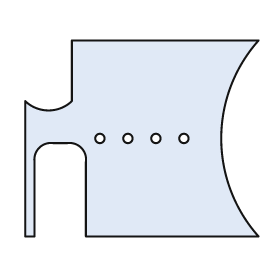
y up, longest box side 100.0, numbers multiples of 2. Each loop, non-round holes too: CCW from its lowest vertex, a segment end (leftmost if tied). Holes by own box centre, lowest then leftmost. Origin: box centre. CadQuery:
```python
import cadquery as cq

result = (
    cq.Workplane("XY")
    .moveTo(-50.0, -42.0)
    .lineTo(-46.0, -42.0)
    .lineTo(-46.0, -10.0)
    .threePointArc((-44.0, -4.0), (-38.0, -2.0))
    .lineTo(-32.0, -2.0)
    .threePointArc((-26.0, -4.0), (-24.0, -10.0))
    .lineTo(-24.0, -42.0)
    .lineTo(50.0, -42.0)
    .threePointArc((34.0, 0.0), (50.0, 42.0))
    .lineTo(-30.0, 42.0)
    .lineTo(-30.0, 16.0)
    .threePointArc((-40.0, 12.0), (-50.0, 16.0))
    .close()
    .moveTo(-18.0, 0.0)
    .circle(2.0)
    .moveTo(-6.0, 0.0)
    .circle(2.0)
    .moveTo(6.0, 0.0)
    .circle(2.0)
    .moveTo(18.0, 0.0)
    .circle(2.0)
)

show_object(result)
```